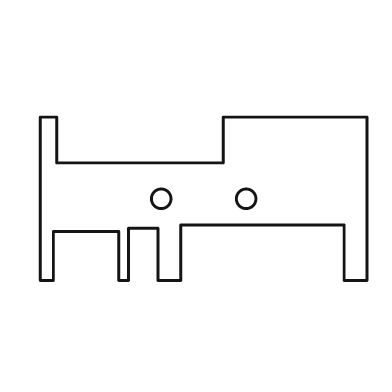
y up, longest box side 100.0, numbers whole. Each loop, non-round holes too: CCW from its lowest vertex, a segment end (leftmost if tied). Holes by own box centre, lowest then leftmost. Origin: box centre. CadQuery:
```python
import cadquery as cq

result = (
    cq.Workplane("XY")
    .moveTo(-50.0, -25.0)
    .lineTo(-46.0, -25.0)
    .lineTo(-46.0, -10.0)
    .lineTo(-26.0, -10.0)
    .lineTo(-26.0, -25.0)
    .lineTo(-23.0, -25.0)
    .lineTo(-23.0, -9.0)
    .lineTo(-14.0, -9.0)
    .lineTo(-14.0, -25.0)
    .lineTo(-7.0, -25.0)
    .lineTo(-7.0, -8.0)
    .lineTo(43.0, -8.0)
    .lineTo(43.0, -25.0)
    .lineTo(50.0, -25.0)
    .lineTo(50.0, 25.0)
    .lineTo(6.0, 25.0)
    .lineTo(6.0, 11.0)
    .lineTo(-45.0, 11.0)
    .lineTo(-45.0, 25.0)
    .lineTo(-50.0, 25.0)
    .close()
    .moveTo(-13.0, 0.0)
    .circle(3.0)
    .moveTo(13.0, 0.0)
    .circle(3.0)
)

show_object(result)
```